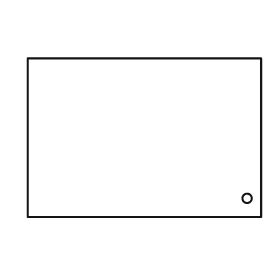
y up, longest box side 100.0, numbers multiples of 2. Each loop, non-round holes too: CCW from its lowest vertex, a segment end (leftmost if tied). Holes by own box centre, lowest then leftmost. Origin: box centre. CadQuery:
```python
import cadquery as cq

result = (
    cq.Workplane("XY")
    .moveTo(-50.0, -34.0)
    .lineTo(50.0, -34.0)
    .lineTo(50.0, 34.0)
    .lineTo(-50.0, 34.0)
    .close()
    .moveTo(44.0, -26.0)
    .circle(2.0)
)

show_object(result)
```